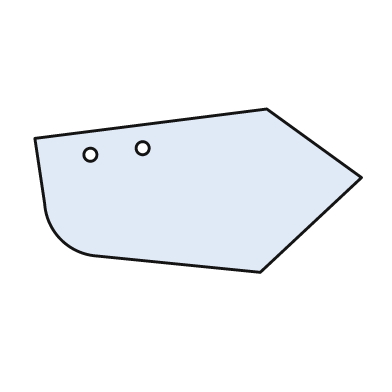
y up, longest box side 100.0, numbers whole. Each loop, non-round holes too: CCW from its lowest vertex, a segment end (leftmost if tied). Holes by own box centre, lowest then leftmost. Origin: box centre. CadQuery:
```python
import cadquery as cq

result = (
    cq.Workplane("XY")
    .moveTo(19.0, -25.0)
    .lineTo(50.0, 4.0)
    .lineTo(21.0, 25.0)
    .lineTo(-50.0, 16.0)
    .lineTo(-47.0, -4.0)
    .threePointArc((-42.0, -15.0), (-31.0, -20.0))
    .close()
    .moveTo(-33.0, 11.0)
    .circle(2.0)
    .moveTo(-17.0, 13.0)
    .circle(2.0)
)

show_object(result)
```